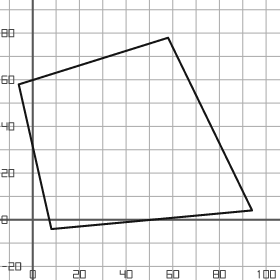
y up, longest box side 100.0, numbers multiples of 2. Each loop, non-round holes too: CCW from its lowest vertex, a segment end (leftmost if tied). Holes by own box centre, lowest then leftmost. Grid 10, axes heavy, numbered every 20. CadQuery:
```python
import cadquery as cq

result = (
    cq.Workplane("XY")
    .moveTo(8.0, -4.0)
    .lineTo(94.0, 4.0)
    .lineTo(58.0, 78.0)
    .lineTo(-6.0, 58.0)
    .close()
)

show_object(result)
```